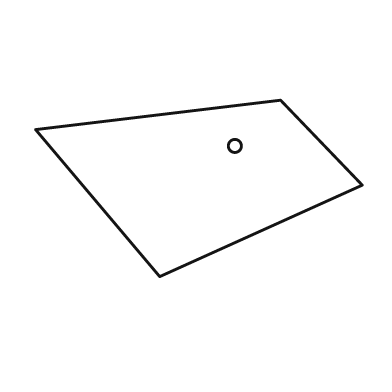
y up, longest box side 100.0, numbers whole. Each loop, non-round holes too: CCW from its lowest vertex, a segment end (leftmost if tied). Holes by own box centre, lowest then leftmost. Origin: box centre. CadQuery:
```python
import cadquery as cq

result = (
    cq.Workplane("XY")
    .moveTo(-12.0, -27.0)
    .lineTo(50.0, 1.0)
    .lineTo(25.0, 27.0)
    .lineTo(-50.0, 18.0)
    .close()
    .moveTo(11.0, 13.0)
    .circle(2.0)
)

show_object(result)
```